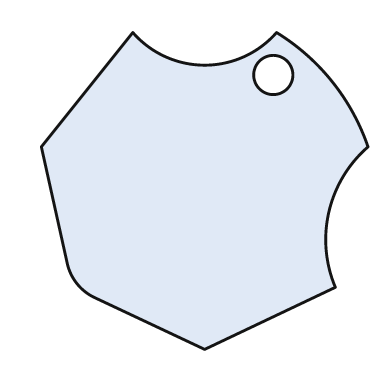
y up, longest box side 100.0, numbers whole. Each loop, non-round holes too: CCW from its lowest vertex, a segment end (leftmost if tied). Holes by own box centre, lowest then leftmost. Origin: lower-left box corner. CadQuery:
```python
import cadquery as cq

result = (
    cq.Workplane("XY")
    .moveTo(50.0, 0.0)
    .lineTo(90.0, 19.0)
    .threePointArc((88.0, 42.0), (100.0, 62.0))
    .threePointArc((89.0, 82.0), (72.0, 97.0))
    .threePointArc((50.0, 87.0), (28.0, 97.0))
    .lineTo(0.0, 62.0)
    .lineTo(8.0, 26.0)
    .threePointArc((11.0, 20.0), (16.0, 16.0))
    .close()
    .moveTo(71.0, 84.0)
    .circle(6.0)
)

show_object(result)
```